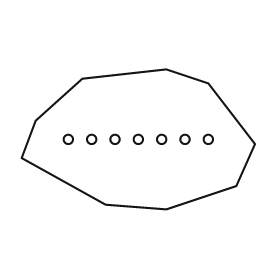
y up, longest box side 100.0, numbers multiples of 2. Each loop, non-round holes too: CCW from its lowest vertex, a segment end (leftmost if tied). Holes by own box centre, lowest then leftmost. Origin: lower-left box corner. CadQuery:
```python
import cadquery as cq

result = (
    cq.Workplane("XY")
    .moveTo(62.0, 0.0)
    .lineTo(92.0, 10.0)
    .lineTo(100.0, 28.0)
    .lineTo(80.0, 54.0)
    .lineTo(62.0, 60.0)
    .lineTo(26.0, 56.0)
    .lineTo(6.0, 38.0)
    .lineTo(0.0, 22.0)
    .lineTo(36.0, 2.0)
    .close()
    .moveTo(20.0, 30.0)
    .circle(2.0)
    .moveTo(30.0, 30.0)
    .circle(2.0)
    .moveTo(40.0, 30.0)
    .circle(2.0)
    .moveTo(50.0, 30.0)
    .circle(2.0)
    .moveTo(60.0, 30.0)
    .circle(2.0)
    .moveTo(70.0, 30.0)
    .circle(2.0)
    .moveTo(80.0, 30.0)
    .circle(2.0)
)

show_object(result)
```